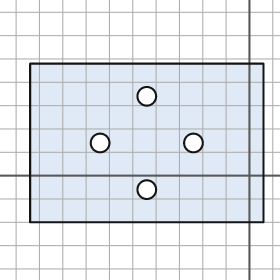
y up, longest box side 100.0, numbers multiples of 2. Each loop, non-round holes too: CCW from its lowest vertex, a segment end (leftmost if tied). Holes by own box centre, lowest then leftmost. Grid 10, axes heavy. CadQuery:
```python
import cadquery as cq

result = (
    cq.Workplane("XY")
    .moveTo(-94.0, -20.0)
    .lineTo(6.0, -20.0)
    .lineTo(6.0, 48.0)
    .lineTo(-94.0, 48.0)
    .close()
    .moveTo(-44.0, -6.0)
    .circle(4.0)
    .moveTo(-64.0, 14.0)
    .circle(4.0)
    .moveTo(-24.0, 14.0)
    .circle(4.0)
    .moveTo(-44.0, 34.0)
    .circle(4.0)
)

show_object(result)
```